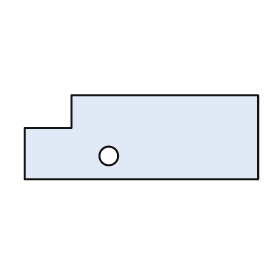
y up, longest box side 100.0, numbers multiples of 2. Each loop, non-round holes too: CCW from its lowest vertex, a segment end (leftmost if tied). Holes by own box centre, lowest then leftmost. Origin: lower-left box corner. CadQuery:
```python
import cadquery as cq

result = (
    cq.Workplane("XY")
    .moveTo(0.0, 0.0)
    .lineTo(100.0, 0.0)
    .lineTo(100.0, 36.0)
    .lineTo(20.0, 36.0)
    .lineTo(20.0, 22.0)
    .lineTo(0.0, 22.0)
    .close()
    .moveTo(36.0, 10.0)
    .circle(4.0)
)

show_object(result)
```